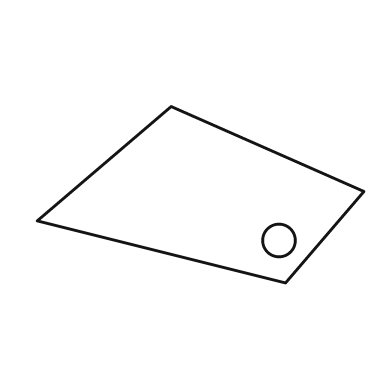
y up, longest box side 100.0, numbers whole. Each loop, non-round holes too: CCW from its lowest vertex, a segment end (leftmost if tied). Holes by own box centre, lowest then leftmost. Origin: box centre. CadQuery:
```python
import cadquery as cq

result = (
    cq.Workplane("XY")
    .moveTo(26.0, -27.0)
    .lineTo(50.0, 1.0)
    .lineTo(-9.0, 27.0)
    .lineTo(-50.0, -8.0)
    .close()
    .moveTo(24.0, -14.0)
    .circle(5.0)
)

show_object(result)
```